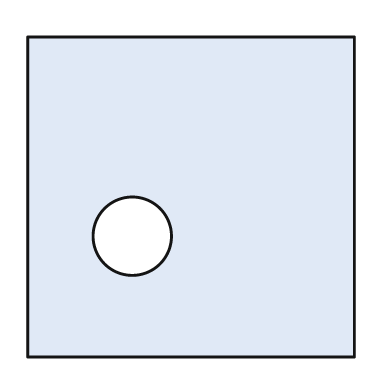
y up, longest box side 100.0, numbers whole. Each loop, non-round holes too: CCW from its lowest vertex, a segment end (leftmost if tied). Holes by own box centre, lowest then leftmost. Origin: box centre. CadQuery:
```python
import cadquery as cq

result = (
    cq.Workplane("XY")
    .moveTo(-50.0, -49.0)
    .lineTo(50.0, -49.0)
    .lineTo(50.0, 49.0)
    .lineTo(-50.0, 49.0)
    .close()
    .moveTo(-18.0, -12.0)
    .circle(12.0)
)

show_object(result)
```